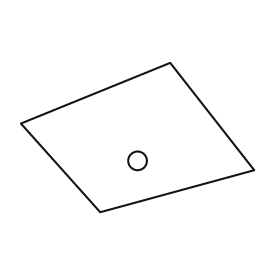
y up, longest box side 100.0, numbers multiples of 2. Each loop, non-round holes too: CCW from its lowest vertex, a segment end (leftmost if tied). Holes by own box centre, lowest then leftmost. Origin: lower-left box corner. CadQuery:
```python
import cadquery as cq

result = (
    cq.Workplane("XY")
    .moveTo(34.0, 0.0)
    .lineTo(100.0, 18.0)
    .lineTo(64.0, 64.0)
    .lineTo(0.0, 38.0)
    .close()
    .moveTo(50.0, 22.0)
    .circle(4.0)
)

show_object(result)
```